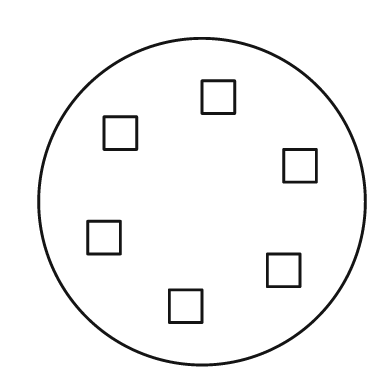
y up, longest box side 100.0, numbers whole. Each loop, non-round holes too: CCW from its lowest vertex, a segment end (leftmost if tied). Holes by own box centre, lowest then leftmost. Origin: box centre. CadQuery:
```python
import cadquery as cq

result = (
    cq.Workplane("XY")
    .moveTo(0.0, 0.0)
    .circle(50.0)
    .moveTo(-10.0, -37.0)
    .lineTo(0.0, -37.0)
    .lineTo(0.0, -27.0)
    .lineTo(-10.0, -27.0)
    .close()
    .moveTo(20.0, -26.0)
    .lineTo(30.0, -26.0)
    .lineTo(30.0, -16.0)
    .lineTo(20.0, -16.0)
    .close()
    .moveTo(-35.0, -16.0)
    .lineTo(-25.0, -16.0)
    .lineTo(-25.0, -6.0)
    .lineTo(-35.0, -6.0)
    .close()
    .moveTo(25.0, 6.0)
    .lineTo(35.0, 6.0)
    .lineTo(35.0, 16.0)
    .lineTo(25.0, 16.0)
    .close()
    .moveTo(-30.0, 16.0)
    .lineTo(-20.0, 16.0)
    .lineTo(-20.0, 26.0)
    .lineTo(-30.0, 26.0)
    .close()
    .moveTo(0.0, 27.0)
    .lineTo(10.0, 27.0)
    .lineTo(10.0, 37.0)
    .lineTo(0.0, 37.0)
    .close()
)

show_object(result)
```